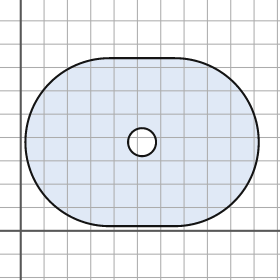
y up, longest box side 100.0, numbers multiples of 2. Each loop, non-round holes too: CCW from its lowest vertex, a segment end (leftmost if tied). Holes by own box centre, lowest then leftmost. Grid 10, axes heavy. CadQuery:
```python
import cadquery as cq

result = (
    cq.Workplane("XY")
    .moveTo(38.0, 2.0)
    .lineTo(66.0, 2.0)
    .threePointArc((102.0, 38.0), (66.0, 74.0))
    .lineTo(38.0, 74.0)
    .threePointArc((2.0, 38.0), (38.0, 2.0))
    .close()
    .moveTo(52.0, 38.0)
    .circle(6.0)
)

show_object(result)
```